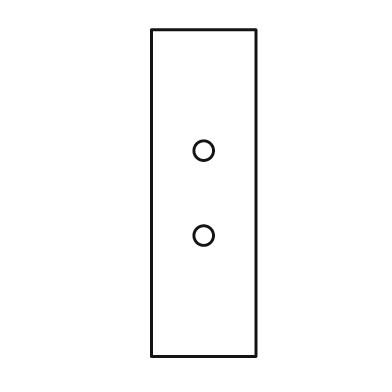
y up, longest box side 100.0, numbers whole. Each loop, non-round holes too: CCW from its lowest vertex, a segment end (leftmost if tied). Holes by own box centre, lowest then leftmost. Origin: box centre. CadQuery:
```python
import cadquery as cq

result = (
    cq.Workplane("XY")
    .moveTo(-16.0, -50.0)
    .lineTo(16.0, -50.0)
    .lineTo(16.0, 50.0)
    .lineTo(-16.0, 50.0)
    .close()
    .moveTo(0.0, -13.0)
    .circle(3.0)
    .moveTo(0.0, 13.0)
    .circle(3.0)
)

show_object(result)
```